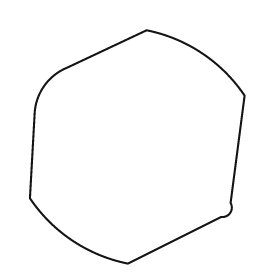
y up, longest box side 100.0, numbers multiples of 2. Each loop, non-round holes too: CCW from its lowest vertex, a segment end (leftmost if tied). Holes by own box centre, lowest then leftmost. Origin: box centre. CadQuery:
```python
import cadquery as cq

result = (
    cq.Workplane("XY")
    .moveTo(-4.0, -50.0)
    .lineTo(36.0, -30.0)
    .threePointArc((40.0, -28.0), (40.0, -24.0))
    .lineTo(46.0, 22.0)
    .threePointArc((28.0, 40.0), (4.0, 50.0))
    .lineTo(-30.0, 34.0)
    .threePointArc((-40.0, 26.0), (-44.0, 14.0))
    .lineTo(-46.0, -22.0)
    .threePointArc((-28.0, -40.0), (-4.0, -50.0))
    .close()
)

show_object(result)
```